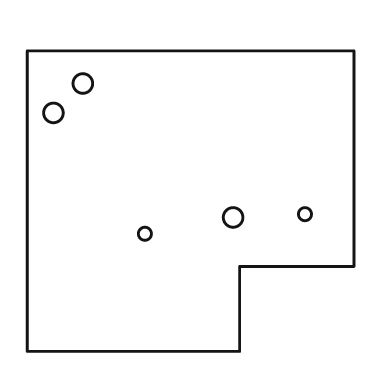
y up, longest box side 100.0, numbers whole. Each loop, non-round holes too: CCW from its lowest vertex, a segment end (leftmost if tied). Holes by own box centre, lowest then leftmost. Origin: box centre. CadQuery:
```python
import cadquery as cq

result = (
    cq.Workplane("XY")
    .moveTo(-50.0, -46.0)
    .lineTo(15.0, -46.0)
    .lineTo(15.0, -20.0)
    .lineTo(50.0, -20.0)
    .lineTo(50.0, 46.0)
    .lineTo(-50.0, 46.0)
    .close()
    .moveTo(-14.0, -10.0)
    .circle(2.0)
    .moveTo(13.0, -5.0)
    .circle(3.0)
    .moveTo(35.0, -4.0)
    .circle(2.0)
    .moveTo(-42.0, 27.0)
    .circle(3.0)
    .moveTo(-33.0, 36.0)
    .circle(3.0)
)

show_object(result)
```